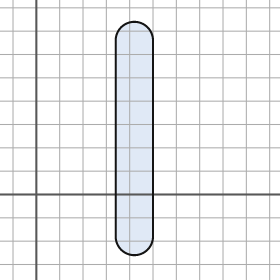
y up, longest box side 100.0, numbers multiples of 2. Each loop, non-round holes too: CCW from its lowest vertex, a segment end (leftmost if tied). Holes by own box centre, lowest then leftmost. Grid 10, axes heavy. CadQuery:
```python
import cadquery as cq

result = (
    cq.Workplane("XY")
    .moveTo(34.0, -18.0)
    .threePointArc((42.0, -26.0), (50.0, -18.0))
    .lineTo(50.0, 66.0)
    .threePointArc((42.0, 74.0), (34.0, 66.0))
    .close()
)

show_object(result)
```